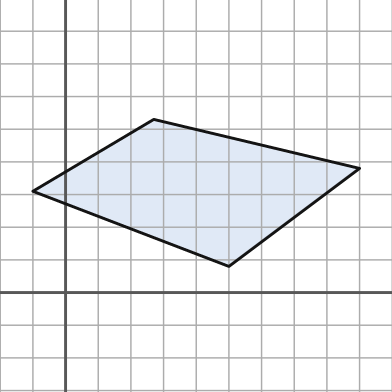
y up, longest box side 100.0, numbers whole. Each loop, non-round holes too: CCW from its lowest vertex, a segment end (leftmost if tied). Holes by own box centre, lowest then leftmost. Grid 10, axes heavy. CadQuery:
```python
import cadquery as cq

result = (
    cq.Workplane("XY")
    .moveTo(50.0, 8.0)
    .lineTo(90.0, 38.0)
    .lineTo(27.0, 53.0)
    .lineTo(-10.0, 31.0)
    .close()
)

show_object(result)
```